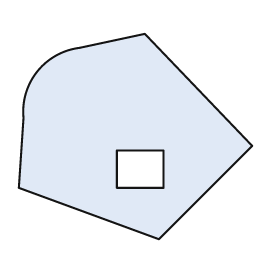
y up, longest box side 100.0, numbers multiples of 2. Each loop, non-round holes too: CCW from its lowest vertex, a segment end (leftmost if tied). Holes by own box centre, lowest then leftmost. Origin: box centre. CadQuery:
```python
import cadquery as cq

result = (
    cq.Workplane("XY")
    .moveTo(10.0, -44.0)
    .lineTo(50.0, -4.0)
    .lineTo(4.0, 44.0)
    .lineTo(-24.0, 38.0)
    .threePointArc((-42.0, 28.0), (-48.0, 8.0))
    .lineTo(-50.0, -22.0)
    .close()
    .moveTo(-8.0, -22.0)
    .lineTo(12.0, -22.0)
    .lineTo(12.0, -6.0)
    .lineTo(-8.0, -6.0)
    .close()
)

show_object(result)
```